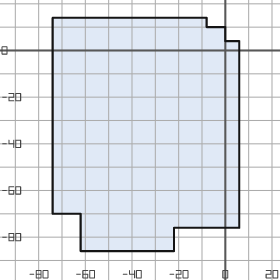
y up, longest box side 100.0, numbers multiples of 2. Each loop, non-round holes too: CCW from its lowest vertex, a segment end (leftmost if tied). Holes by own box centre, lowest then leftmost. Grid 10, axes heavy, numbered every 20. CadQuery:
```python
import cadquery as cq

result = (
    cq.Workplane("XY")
    .moveTo(-62.0, -86.0)
    .lineTo(-22.0, -86.0)
    .lineTo(-22.0, -76.0)
    .lineTo(6.0, -76.0)
    .lineTo(6.0, 4.0)
    .lineTo(0.0, 4.0)
    .lineTo(0.0, 10.0)
    .lineTo(-8.0, 10.0)
    .lineTo(-8.0, 14.0)
    .lineTo(-74.0, 14.0)
    .lineTo(-74.0, -70.0)
    .lineTo(-62.0, -70.0)
    .close()
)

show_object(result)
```